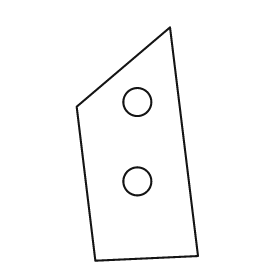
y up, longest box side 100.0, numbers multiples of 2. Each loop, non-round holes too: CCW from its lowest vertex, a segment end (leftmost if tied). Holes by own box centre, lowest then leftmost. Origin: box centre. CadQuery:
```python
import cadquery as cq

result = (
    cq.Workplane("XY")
    .moveTo(-18.0, -50.0)
    .lineTo(26.0, -48.0)
    .lineTo(14.0, 50.0)
    .lineTo(-26.0, 16.0)
    .close()
    .moveTo(0.0, -16.0)
    .circle(6.0)
    .moveTo(0.0, 18.0)
    .circle(6.0)
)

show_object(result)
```